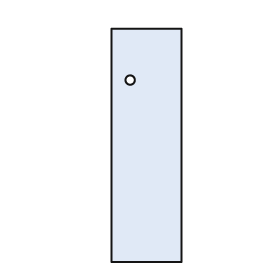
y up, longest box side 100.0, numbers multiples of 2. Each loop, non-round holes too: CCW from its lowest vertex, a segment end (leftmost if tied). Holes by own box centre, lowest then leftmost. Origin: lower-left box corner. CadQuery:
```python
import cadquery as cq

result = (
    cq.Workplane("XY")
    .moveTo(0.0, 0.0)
    .lineTo(30.0, 0.0)
    .lineTo(30.0, 100.0)
    .lineTo(0.0, 100.0)
    .close()
    .moveTo(8.0, 78.0)
    .circle(2.0)
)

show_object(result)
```